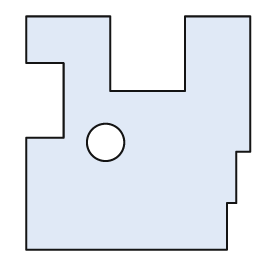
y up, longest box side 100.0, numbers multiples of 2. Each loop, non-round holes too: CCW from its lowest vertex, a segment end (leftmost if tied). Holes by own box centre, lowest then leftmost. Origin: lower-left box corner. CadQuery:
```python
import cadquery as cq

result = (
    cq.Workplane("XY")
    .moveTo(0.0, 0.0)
    .lineTo(86.0, 0.0)
    .lineTo(86.0, 20.0)
    .lineTo(90.0, 20.0)
    .lineTo(90.0, 42.0)
    .lineTo(96.0, 42.0)
    .lineTo(96.0, 100.0)
    .lineTo(68.0, 100.0)
    .lineTo(68.0, 68.0)
    .lineTo(36.0, 68.0)
    .lineTo(36.0, 100.0)
    .lineTo(0.0, 100.0)
    .lineTo(0.0, 80.0)
    .lineTo(16.0, 80.0)
    .lineTo(16.0, 48.0)
    .lineTo(0.0, 48.0)
    .close()
    .moveTo(34.0, 46.0)
    .circle(8.0)
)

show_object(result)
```